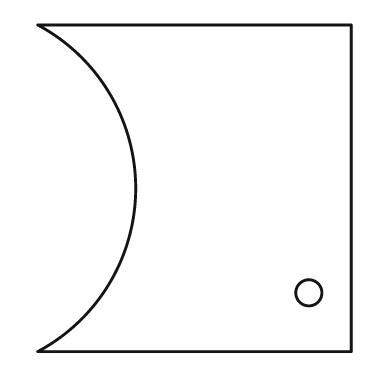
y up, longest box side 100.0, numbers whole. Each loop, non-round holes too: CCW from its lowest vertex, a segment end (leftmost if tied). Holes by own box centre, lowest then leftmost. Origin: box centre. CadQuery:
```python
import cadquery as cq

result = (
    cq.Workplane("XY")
    .moveTo(-48.0, -50.0)
    .lineTo(48.0, -50.0)
    .lineTo(48.0, 50.0)
    .lineTo(-48.0, 50.0)
    .threePointArc((-18.0, 0.0), (-48.0, -50.0))
    .close()
    .moveTo(35.0, -32.0)
    .circle(4.0)
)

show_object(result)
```